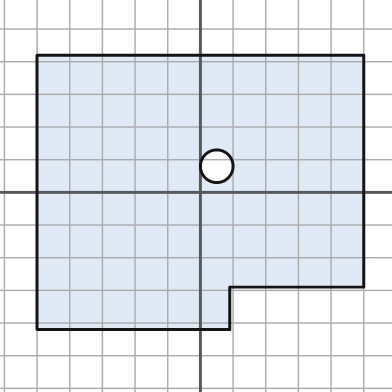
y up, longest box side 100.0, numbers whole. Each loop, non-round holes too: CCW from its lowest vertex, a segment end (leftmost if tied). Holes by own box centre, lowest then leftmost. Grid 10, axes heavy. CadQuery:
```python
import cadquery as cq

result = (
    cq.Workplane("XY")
    .moveTo(-50.0, -42.0)
    .lineTo(9.0, -42.0)
    .lineTo(9.0, -29.0)
    .lineTo(50.0, -29.0)
    .lineTo(50.0, 42.0)
    .lineTo(-50.0, 42.0)
    .close()
    .moveTo(5.0, 8.0)
    .circle(5.0)
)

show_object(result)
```